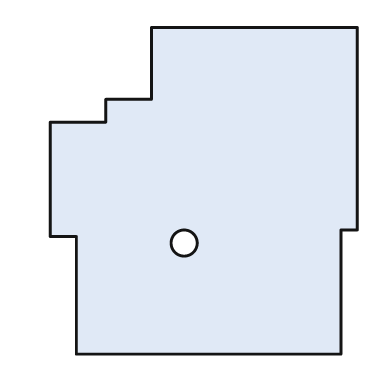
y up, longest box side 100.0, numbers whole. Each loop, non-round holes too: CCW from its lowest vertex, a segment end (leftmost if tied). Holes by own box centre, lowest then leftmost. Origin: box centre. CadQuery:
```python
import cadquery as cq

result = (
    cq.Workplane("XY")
    .moveTo(-39.0, -50.0)
    .lineTo(42.0, -50.0)
    .lineTo(42.0, -12.0)
    .lineTo(47.0, -12.0)
    .lineTo(47.0, 50.0)
    .lineTo(-16.0, 50.0)
    .lineTo(-16.0, 28.0)
    .lineTo(-30.0, 28.0)
    .lineTo(-30.0, 21.0)
    .lineTo(-47.0, 21.0)
    .lineTo(-47.0, -14.0)
    .lineTo(-39.0, -14.0)
    .close()
    .moveTo(-6.0, -16.0)
    .circle(4.0)
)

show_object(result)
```